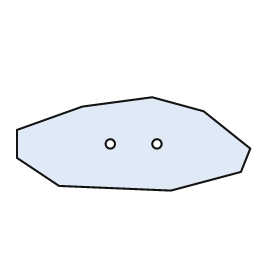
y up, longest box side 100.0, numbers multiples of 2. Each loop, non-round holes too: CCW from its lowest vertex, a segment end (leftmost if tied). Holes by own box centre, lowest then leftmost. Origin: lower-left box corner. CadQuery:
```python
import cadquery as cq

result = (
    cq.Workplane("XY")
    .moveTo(66.0, 0.0)
    .lineTo(96.0, 8.0)
    .lineTo(100.0, 18.0)
    .lineTo(80.0, 34.0)
    .lineTo(58.0, 40.0)
    .lineTo(28.0, 36.0)
    .lineTo(0.0, 26.0)
    .lineTo(0.0, 14.0)
    .lineTo(18.0, 2.0)
    .close()
    .moveTo(40.0, 20.0)
    .circle(2.0)
    .moveTo(60.0, 20.0)
    .circle(2.0)
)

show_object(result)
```